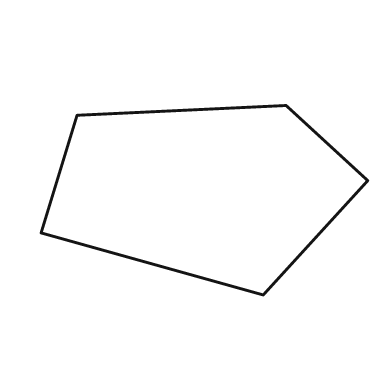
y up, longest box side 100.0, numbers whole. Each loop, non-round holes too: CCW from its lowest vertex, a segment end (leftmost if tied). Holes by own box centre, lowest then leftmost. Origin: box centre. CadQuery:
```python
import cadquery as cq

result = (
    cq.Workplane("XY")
    .moveTo(18.0, -29.0)
    .lineTo(50.0, 6.0)
    .lineTo(25.0, 29.0)
    .lineTo(-39.0, 26.0)
    .lineTo(-50.0, -10.0)
    .close()
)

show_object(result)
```